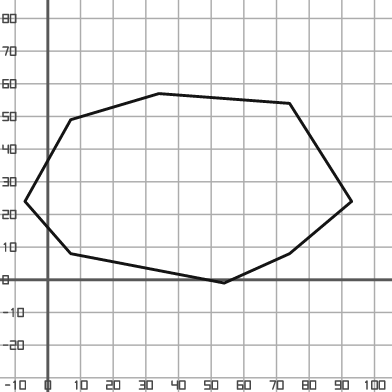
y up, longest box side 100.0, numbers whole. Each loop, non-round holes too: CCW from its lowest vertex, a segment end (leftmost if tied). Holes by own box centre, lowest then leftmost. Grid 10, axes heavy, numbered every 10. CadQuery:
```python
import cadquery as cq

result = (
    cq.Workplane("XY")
    .moveTo(54.0, -1.0)
    .lineTo(74.0, 8.0)
    .lineTo(93.0, 24.0)
    .lineTo(74.0, 54.0)
    .lineTo(34.0, 57.0)
    .lineTo(7.0, 49.0)
    .lineTo(-7.0, 24.0)
    .lineTo(7.0, 8.0)
    .close()
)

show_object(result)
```